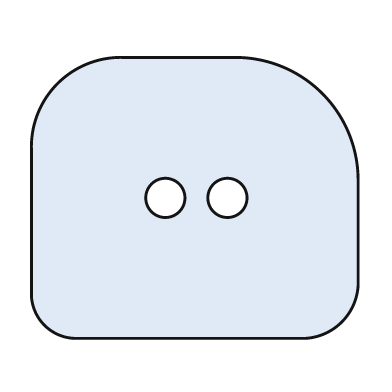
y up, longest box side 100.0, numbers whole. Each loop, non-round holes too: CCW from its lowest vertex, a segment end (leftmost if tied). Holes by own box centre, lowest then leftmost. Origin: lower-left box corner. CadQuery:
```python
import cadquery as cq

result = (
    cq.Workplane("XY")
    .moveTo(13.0, 0.0)
    .lineTo(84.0, 0.0)
    .threePointArc((95.0, 5.0), (100.0, 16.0))
    .lineTo(100.0, 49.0)
    .threePointArc((89.0, 75.0), (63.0, 86.0))
    .lineTo(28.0, 86.0)
    .threePointArc((8.0, 78.0), (0.0, 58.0))
    .lineTo(0.0, 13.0)
    .threePointArc((4.0, 4.0), (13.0, 0.0))
    .close()
    .moveTo(41.0, 43.0)
    .circle(6.0)
    .moveTo(60.0, 43.0)
    .circle(6.0)
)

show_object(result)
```